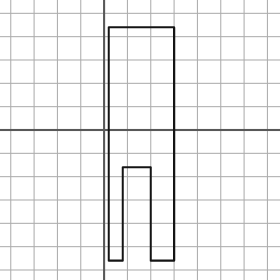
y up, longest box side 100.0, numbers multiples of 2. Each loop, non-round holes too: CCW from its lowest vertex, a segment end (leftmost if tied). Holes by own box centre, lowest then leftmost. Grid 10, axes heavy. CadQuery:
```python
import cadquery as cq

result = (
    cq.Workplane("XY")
    .moveTo(2.0, -56.0)
    .lineTo(8.0, -56.0)
    .lineTo(8.0, -16.0)
    .lineTo(20.0, -16.0)
    .lineTo(20.0, -56.0)
    .lineTo(30.0, -56.0)
    .lineTo(30.0, 44.0)
    .lineTo(2.0, 44.0)
    .close()
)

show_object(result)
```